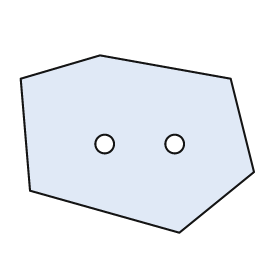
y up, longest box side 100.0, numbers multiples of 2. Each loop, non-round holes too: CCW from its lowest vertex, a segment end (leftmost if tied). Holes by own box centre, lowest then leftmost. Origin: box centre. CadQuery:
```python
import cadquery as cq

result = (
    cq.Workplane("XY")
    .moveTo(18.0, -38.0)
    .lineTo(50.0, -12.0)
    .lineTo(40.0, 28.0)
    .lineTo(-16.0, 38.0)
    .lineTo(-50.0, 28.0)
    .lineTo(-46.0, -20.0)
    .close()
    .moveTo(-14.0, 0.0)
    .circle(4.0)
    .moveTo(16.0, 0.0)
    .circle(4.0)
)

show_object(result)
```